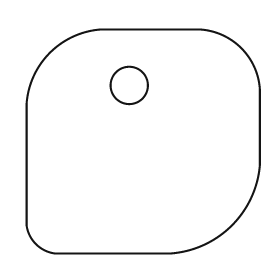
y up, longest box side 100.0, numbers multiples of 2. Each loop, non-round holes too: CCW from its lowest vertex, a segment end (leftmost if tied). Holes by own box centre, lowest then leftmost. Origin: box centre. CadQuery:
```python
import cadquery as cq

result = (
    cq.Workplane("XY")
    .moveTo(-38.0, -48.0)
    .lineTo(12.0, -48.0)
    .threePointArc((38.0, -36.0), (50.0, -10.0))
    .lineTo(50.0, 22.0)
    .threePointArc((42.0, 40.0), (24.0, 48.0))
    .lineTo(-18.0, 48.0)
    .threePointArc((-40.0, 38.0), (-50.0, 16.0))
    .lineTo(-50.0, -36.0)
    .threePointArc((-46.0, -44.0), (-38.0, -48.0))
    .close()
    .moveTo(-6.0, 24.0)
    .circle(8.0)
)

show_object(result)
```